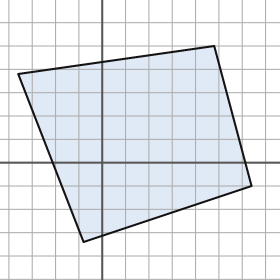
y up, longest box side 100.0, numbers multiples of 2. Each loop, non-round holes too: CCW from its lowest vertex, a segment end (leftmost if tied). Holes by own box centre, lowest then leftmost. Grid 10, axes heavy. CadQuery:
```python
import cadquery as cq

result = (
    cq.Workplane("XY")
    .moveTo(-8.0, -34.0)
    .lineTo(64.0, -10.0)
    .lineTo(48.0, 50.0)
    .lineTo(-36.0, 38.0)
    .close()
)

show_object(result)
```